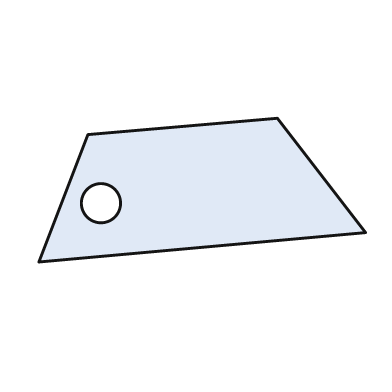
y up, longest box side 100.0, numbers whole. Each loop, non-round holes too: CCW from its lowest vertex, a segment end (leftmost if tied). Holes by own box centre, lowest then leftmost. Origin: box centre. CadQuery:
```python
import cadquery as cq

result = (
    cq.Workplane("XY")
    .moveTo(-50.0, -22.0)
    .lineTo(50.0, -13.0)
    .lineTo(23.0, 22.0)
    .lineTo(-35.0, 17.0)
    .close()
    .moveTo(-31.0, -4.0)
    .circle(6.0)
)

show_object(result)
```